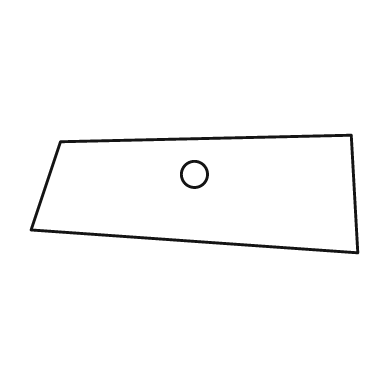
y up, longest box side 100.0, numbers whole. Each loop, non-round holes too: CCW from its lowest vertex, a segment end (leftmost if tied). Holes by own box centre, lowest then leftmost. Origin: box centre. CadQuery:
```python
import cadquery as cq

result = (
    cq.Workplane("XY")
    .moveTo(50.0, -18.0)
    .lineTo(48.0, 18.0)
    .lineTo(-41.0, 16.0)
    .lineTo(-50.0, -11.0)
    .close()
    .moveTo(0.0, 6.0)
    .circle(4.0)
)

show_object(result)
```